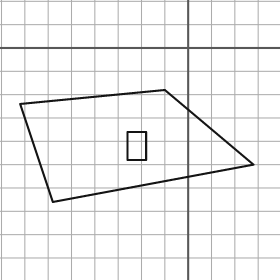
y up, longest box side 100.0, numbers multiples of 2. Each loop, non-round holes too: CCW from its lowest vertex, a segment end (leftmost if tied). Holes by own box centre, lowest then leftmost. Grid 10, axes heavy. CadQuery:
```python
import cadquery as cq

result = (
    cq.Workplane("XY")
    .moveTo(-58.0, -66.0)
    .lineTo(28.0, -50.0)
    .lineTo(-10.0, -18.0)
    .lineTo(-72.0, -24.0)
    .close()
    .moveTo(-26.0, -48.0)
    .lineTo(-18.0, -48.0)
    .lineTo(-18.0, -36.0)
    .lineTo(-26.0, -36.0)
    .close()
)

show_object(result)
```